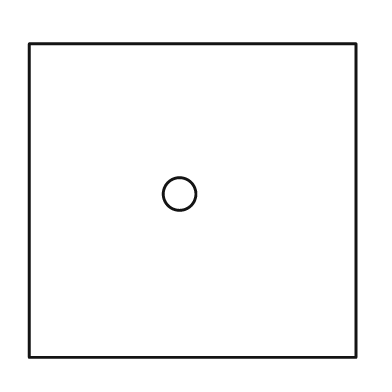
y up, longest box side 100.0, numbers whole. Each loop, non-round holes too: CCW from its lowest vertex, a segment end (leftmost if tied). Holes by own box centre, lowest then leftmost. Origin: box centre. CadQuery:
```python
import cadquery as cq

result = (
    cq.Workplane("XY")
    .moveTo(-50.0, -48.0)
    .lineTo(50.0, -48.0)
    .lineTo(50.0, 48.0)
    .lineTo(-50.0, 48.0)
    .close()
    .moveTo(-4.0, 2.0)
    .circle(5.0)
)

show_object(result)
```